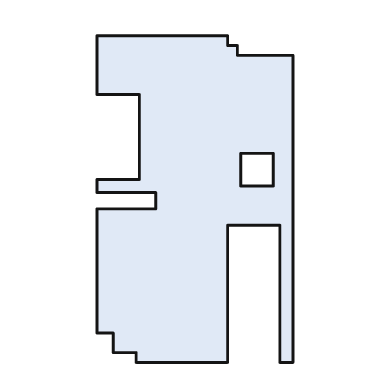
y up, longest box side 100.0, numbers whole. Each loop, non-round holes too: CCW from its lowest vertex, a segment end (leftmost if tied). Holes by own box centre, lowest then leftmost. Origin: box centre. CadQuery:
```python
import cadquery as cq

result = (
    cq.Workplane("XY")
    .moveTo(-18.0, -50.0)
    .lineTo(10.0, -50.0)
    .lineTo(10.0, -8.0)
    .lineTo(26.0, -8.0)
    .lineTo(26.0, -50.0)
    .lineTo(30.0, -50.0)
    .lineTo(30.0, 44.0)
    .lineTo(13.0, 44.0)
    .lineTo(13.0, 47.0)
    .lineTo(10.0, 47.0)
    .lineTo(10.0, 50.0)
    .lineTo(-30.0, 50.0)
    .lineTo(-30.0, 32.0)
    .lineTo(-17.0, 32.0)
    .lineTo(-17.0, 6.0)
    .lineTo(-30.0, 6.0)
    .lineTo(-30.0, 2.0)
    .lineTo(-12.0, 2.0)
    .lineTo(-12.0, -3.0)
    .lineTo(-30.0, -3.0)
    .lineTo(-30.0, -41.0)
    .lineTo(-25.0, -41.0)
    .lineTo(-25.0, -47.0)
    .lineTo(-18.0, -47.0)
    .close()
    .moveTo(14.0, 4.0)
    .lineTo(24.0, 4.0)
    .lineTo(24.0, 14.0)
    .lineTo(14.0, 14.0)
    .close()
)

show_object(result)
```